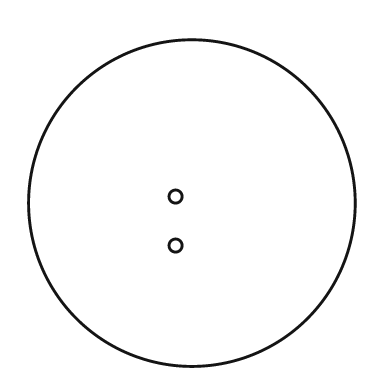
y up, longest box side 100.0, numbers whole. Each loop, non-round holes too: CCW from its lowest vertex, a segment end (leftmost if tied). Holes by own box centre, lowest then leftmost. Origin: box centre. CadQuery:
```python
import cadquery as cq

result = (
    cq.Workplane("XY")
    .moveTo(0.0, 0.0)
    .circle(50.0)
    .moveTo(-5.0, -13.0)
    .circle(2.0)
    .moveTo(-5.0, 2.0)
    .circle(2.0)
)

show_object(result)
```